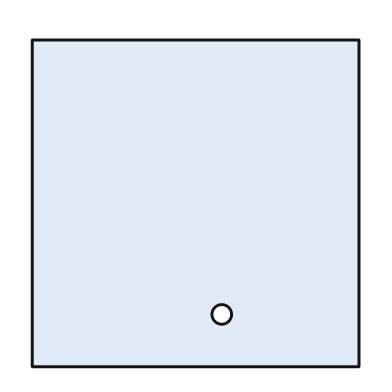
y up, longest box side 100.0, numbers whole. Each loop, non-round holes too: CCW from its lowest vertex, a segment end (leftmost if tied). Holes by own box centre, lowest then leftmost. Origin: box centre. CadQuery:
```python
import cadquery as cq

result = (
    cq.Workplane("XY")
    .moveTo(-50.0, -50.0)
    .lineTo(50.0, -50.0)
    .lineTo(50.0, 50.0)
    .lineTo(-50.0, 50.0)
    .close()
    .moveTo(8.0, -34.0)
    .circle(3.0)
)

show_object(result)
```